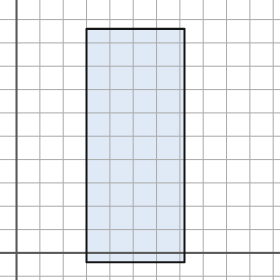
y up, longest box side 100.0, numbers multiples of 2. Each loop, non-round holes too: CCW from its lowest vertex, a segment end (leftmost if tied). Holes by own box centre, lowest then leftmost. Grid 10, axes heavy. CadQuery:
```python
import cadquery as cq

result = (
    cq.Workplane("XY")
    .moveTo(30.0, -4.0)
    .lineTo(72.0, -4.0)
    .lineTo(72.0, 96.0)
    .lineTo(30.0, 96.0)
    .close()
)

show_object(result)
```